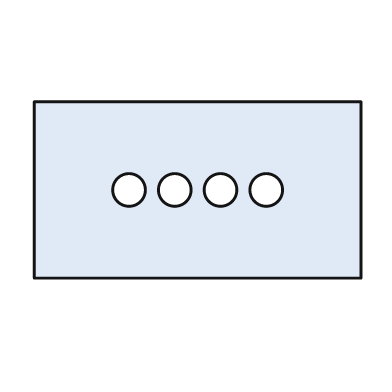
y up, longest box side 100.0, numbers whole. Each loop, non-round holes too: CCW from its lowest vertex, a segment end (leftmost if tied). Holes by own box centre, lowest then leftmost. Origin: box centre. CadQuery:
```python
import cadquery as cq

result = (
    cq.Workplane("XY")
    .moveTo(-50.0, -27.0)
    .lineTo(50.0, -27.0)
    .lineTo(50.0, 27.0)
    .lineTo(-50.0, 27.0)
    .close()
    .moveTo(-21.0, 0.0)
    .circle(5.0)
    .moveTo(-7.0, 0.0)
    .circle(5.0)
    .moveTo(7.0, 0.0)
    .circle(5.0)
    .moveTo(21.0, 0.0)
    .circle(5.0)
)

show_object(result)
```